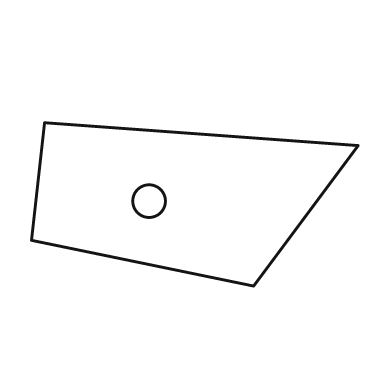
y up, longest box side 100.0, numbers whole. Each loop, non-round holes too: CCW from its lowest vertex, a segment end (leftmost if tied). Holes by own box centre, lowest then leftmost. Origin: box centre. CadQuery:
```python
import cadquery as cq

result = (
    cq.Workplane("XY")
    .moveTo(18.0, -25.0)
    .lineTo(50.0, 18.0)
    .lineTo(-46.0, 25.0)
    .lineTo(-50.0, -11.0)
    .close()
    .moveTo(-14.0, 1.0)
    .circle(5.0)
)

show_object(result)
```